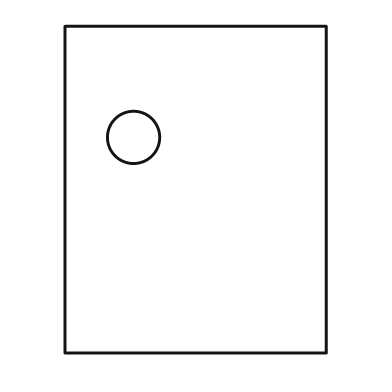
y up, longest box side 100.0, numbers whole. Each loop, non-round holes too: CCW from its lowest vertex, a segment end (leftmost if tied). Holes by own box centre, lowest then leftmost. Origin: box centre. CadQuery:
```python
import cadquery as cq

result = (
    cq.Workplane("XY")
    .moveTo(-40.0, -50.0)
    .lineTo(40.0, -50.0)
    .lineTo(40.0, 50.0)
    .lineTo(-40.0, 50.0)
    .close()
    .moveTo(-19.0, 16.0)
    .circle(8.0)
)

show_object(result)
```